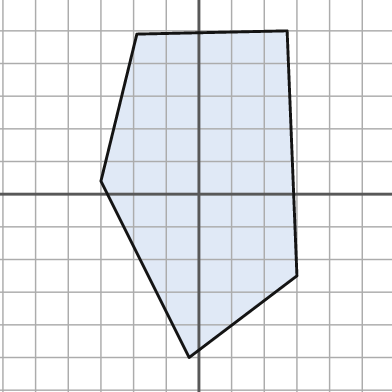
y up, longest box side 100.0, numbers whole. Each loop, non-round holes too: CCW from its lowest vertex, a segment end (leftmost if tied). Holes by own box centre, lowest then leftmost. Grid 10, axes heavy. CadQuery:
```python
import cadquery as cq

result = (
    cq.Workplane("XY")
    .moveTo(-3.0, -50.0)
    .lineTo(30.0, -25.0)
    .lineTo(27.0, 50.0)
    .lineTo(-19.0, 49.0)
    .lineTo(-30.0, 4.0)
    .close()
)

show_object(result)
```